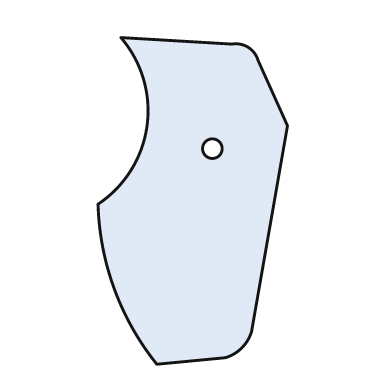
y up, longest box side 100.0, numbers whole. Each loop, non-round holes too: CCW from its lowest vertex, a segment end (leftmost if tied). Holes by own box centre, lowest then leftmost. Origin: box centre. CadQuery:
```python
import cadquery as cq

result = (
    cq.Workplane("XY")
    .moveTo(-11.0, -50.0)
    .lineTo(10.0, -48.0)
    .threePointArc((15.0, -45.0), (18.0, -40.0))
    .lineTo(29.0, 23.0)
    .lineTo(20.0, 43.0)
    .threePointArc((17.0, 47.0), (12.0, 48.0))
    .lineTo(-22.0, 50.0)
    .threePointArc((-14.0, 23.0), (-29.0, -1.0))
    .threePointArc((-24.0, -27.0), (-11.0, -50.0))
    .close()
    .moveTo(6.0, 16.0)
    .circle(3.0)
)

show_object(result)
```